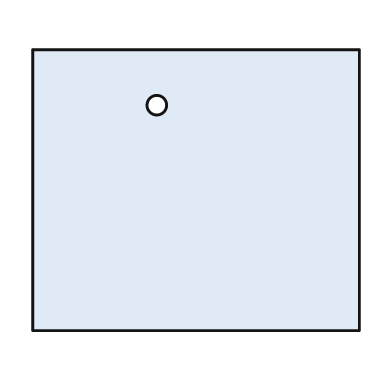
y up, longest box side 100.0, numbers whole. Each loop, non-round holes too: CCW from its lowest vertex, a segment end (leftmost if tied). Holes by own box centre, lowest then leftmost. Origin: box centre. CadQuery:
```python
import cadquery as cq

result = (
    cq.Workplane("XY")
    .moveTo(-50.0, -43.0)
    .lineTo(50.0, -43.0)
    .lineTo(50.0, 43.0)
    .lineTo(-50.0, 43.0)
    .close()
    .moveTo(-12.0, 26.0)
    .circle(3.0)
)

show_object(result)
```